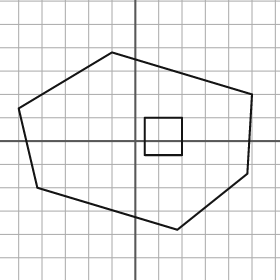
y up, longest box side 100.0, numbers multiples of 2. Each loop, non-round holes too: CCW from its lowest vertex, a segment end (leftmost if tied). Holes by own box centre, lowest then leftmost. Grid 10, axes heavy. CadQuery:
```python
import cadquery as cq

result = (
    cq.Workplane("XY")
    .moveTo(18.0, -38.0)
    .lineTo(48.0, -14.0)
    .lineTo(50.0, 20.0)
    .lineTo(-10.0, 38.0)
    .lineTo(-50.0, 14.0)
    .lineTo(-42.0, -20.0)
    .close()
    .moveTo(4.0, -6.0)
    .lineTo(20.0, -6.0)
    .lineTo(20.0, 10.0)
    .lineTo(4.0, 10.0)
    .close()
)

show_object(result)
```